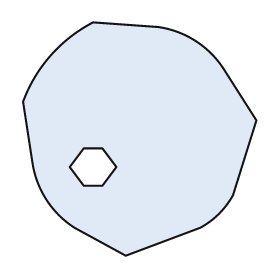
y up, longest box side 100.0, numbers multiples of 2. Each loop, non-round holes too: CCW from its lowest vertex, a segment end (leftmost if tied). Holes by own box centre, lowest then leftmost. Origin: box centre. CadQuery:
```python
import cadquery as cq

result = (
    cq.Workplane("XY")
    .moveTo(-6.0, -50.0)
    .lineTo(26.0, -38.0)
    .threePointArc((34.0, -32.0), (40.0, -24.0))
    .lineTo(50.0, 8.0)
    .lineTo(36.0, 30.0)
    .threePointArc((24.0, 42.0), (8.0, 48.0))
    .lineTo(-20.0, 50.0)
    .threePointArc((-38.0, 36.0), (-50.0, 16.0))
    .lineTo(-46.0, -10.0)
    .threePointArc((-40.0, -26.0), (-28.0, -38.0))
    .close()
    .moveTo(-24.0, -20.0)
    .lineTo(-16.0, -20.0)
    .lineTo(-10.0, -12.0)
    .lineTo(-16.0, -4.0)
    .lineTo(-24.0, -4.0)
    .lineTo(-30.0, -12.0)
    .close()
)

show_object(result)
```